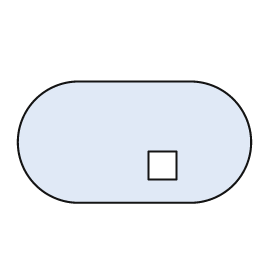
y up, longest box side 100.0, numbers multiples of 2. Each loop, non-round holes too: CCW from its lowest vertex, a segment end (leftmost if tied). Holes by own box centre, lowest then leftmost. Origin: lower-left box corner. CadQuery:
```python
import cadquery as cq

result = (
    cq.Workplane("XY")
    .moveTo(26.0, 0.0)
    .lineTo(74.0, 0.0)
    .threePointArc((100.0, 26.0), (74.0, 52.0))
    .lineTo(26.0, 52.0)
    .threePointArc((0.0, 26.0), (26.0, 0.0))
    .close()
    .moveTo(56.0, 10.0)
    .lineTo(68.0, 10.0)
    .lineTo(68.0, 22.0)
    .lineTo(56.0, 22.0)
    .close()
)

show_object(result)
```